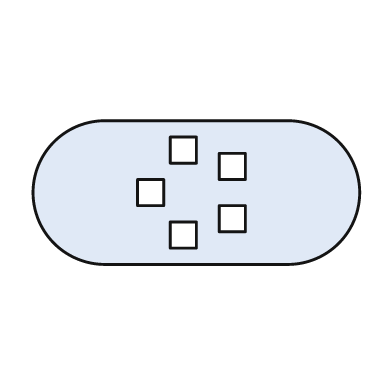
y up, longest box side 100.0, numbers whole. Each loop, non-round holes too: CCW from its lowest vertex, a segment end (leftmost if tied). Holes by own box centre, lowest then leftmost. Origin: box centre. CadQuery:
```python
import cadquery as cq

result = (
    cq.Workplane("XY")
    .moveTo(-28.0, -22.0)
    .lineTo(28.0, -22.0)
    .threePointArc((50.0, 0.0), (28.0, 22.0))
    .lineTo(-28.0, 22.0)
    .threePointArc((-50.0, 0.0), (-28.0, -22.0))
    .close()
    .moveTo(-8.0, -17.0)
    .lineTo(0.0, -17.0)
    .lineTo(0.0, -9.0)
    .lineTo(-8.0, -9.0)
    .close()
    .moveTo(7.0, -12.0)
    .lineTo(15.0, -12.0)
    .lineTo(15.0, -4.0)
    .lineTo(7.0, -4.0)
    .close()
    .moveTo(-18.0, -4.0)
    .lineTo(-10.0, -4.0)
    .lineTo(-10.0, 4.0)
    .lineTo(-18.0, 4.0)
    .close()
    .moveTo(7.0, 4.0)
    .lineTo(15.0, 4.0)
    .lineTo(15.0, 12.0)
    .lineTo(7.0, 12.0)
    .close()
    .moveTo(-8.0, 9.0)
    .lineTo(0.0, 9.0)
    .lineTo(0.0, 17.0)
    .lineTo(-8.0, 17.0)
    .close()
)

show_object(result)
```